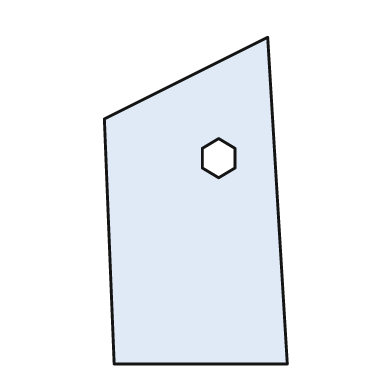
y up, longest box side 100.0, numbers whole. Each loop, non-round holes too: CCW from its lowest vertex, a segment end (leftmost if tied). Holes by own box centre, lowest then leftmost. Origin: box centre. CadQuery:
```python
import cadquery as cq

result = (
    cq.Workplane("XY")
    .moveTo(-25.0, -50.0)
    .lineTo(28.0, -50.0)
    .lineTo(22.0, 50.0)
    .lineTo(-28.0, 25.0)
    .close()
    .moveTo(7.0, 7.0)
    .lineTo(12.0, 10.0)
    .lineTo(12.0, 16.0)
    .lineTo(7.0, 19.0)
    .lineTo(2.0, 16.0)
    .lineTo(2.0, 10.0)
    .close()
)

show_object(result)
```